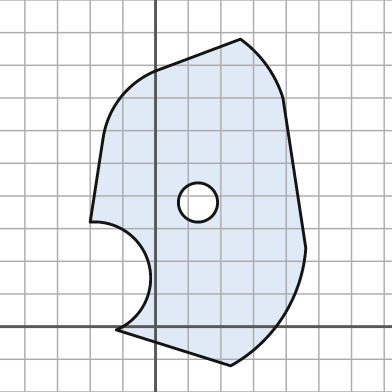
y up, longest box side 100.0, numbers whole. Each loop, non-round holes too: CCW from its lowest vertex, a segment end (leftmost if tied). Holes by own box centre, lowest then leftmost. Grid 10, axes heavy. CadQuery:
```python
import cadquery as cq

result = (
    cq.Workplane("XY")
    .moveTo(23.0, -12.0)
    .threePointArc((39.0, 3.0), (46.0, 24.0))
    .lineTo(39.0, 70.0)
    .threePointArc((34.0, 80.0), (26.0, 88.0))
    .lineTo(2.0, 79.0)
    .threePointArc((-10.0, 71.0), (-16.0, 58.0))
    .lineTo(-20.0, 32.0)
    .threePointArc((-2.0, 19.0), (-12.0, -1.0))
    .close()
    .moveTo(13.0, 38.0)
    .circle(6.0)
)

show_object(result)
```